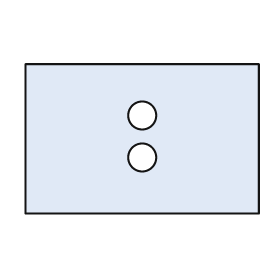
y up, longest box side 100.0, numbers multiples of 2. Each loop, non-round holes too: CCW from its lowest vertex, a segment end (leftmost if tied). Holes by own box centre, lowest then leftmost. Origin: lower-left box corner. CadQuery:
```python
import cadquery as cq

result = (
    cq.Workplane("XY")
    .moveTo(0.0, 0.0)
    .lineTo(100.0, 0.0)
    .lineTo(100.0, 64.0)
    .lineTo(0.0, 64.0)
    .close()
    .moveTo(50.0, 24.0)
    .circle(6.0)
    .moveTo(50.0, 42.0)
    .circle(6.0)
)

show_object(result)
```